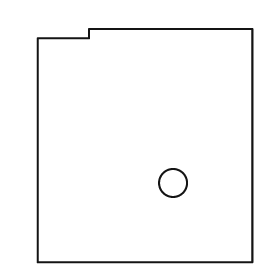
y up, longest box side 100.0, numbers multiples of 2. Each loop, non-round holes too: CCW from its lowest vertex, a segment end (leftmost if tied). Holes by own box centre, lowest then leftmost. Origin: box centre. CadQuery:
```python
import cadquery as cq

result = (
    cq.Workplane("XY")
    .moveTo(-46.0, -50.0)
    .lineTo(46.0, -50.0)
    .lineTo(46.0, 50.0)
    .lineTo(-24.0, 50.0)
    .lineTo(-24.0, 46.0)
    .lineTo(-46.0, 46.0)
    .close()
    .moveTo(12.0, -16.0)
    .circle(6.0)
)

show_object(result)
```